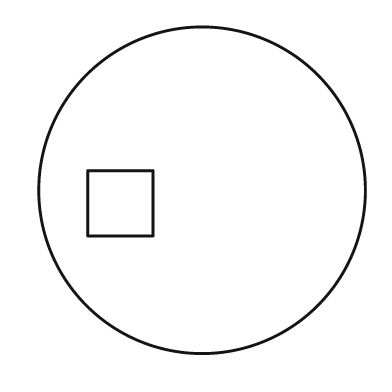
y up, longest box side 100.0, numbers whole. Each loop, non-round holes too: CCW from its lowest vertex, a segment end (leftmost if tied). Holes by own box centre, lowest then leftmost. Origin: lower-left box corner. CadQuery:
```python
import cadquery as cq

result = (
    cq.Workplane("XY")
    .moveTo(50.0, 50.0)
    .circle(50.0)
    .moveTo(15.0, 36.0)
    .lineTo(35.0, 36.0)
    .lineTo(35.0, 56.0)
    .lineTo(15.0, 56.0)
    .close()
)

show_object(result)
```